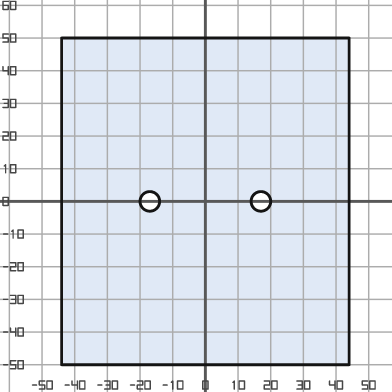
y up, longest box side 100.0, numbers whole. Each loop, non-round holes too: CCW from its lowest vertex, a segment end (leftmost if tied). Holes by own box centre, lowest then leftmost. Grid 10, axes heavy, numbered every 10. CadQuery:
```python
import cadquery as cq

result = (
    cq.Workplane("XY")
    .moveTo(-44.0, -50.0)
    .lineTo(44.0, -50.0)
    .lineTo(44.0, 50.0)
    .lineTo(-44.0, 50.0)
    .close()
    .moveTo(-17.0, 0.0)
    .circle(3.0)
    .moveTo(17.0, 0.0)
    .circle(3.0)
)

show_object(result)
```